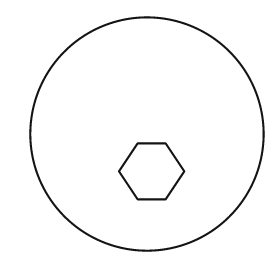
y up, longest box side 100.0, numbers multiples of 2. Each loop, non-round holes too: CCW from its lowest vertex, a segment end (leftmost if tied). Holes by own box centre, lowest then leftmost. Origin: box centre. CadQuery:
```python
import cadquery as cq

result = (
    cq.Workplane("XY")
    .moveTo(0.0, 0.0)
    .circle(50.0)
    .moveTo(-4.0, -28.0)
    .lineTo(8.0, -28.0)
    .lineTo(16.0, -16.0)
    .lineTo(8.0, -4.0)
    .lineTo(-4.0, -4.0)
    .lineTo(-12.0, -16.0)
    .close()
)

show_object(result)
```